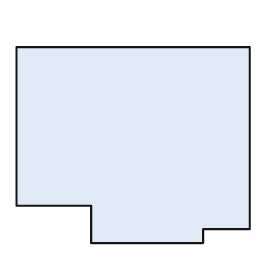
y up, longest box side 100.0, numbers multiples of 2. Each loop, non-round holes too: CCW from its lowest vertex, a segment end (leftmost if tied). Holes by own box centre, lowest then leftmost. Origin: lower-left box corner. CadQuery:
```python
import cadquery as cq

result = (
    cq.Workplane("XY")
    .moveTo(32.0, 0.0)
    .lineTo(80.0, 0.0)
    .lineTo(80.0, 6.0)
    .lineTo(100.0, 6.0)
    .lineTo(100.0, 84.0)
    .lineTo(0.0, 84.0)
    .lineTo(0.0, 16.0)
    .lineTo(32.0, 16.0)
    .close()
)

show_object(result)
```